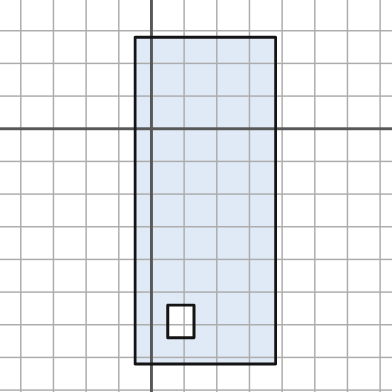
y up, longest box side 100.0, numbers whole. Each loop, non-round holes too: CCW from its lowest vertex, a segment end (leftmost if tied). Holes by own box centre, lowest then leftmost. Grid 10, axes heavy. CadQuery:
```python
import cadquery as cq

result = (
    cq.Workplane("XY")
    .moveTo(-5.0, -72.0)
    .lineTo(38.0, -72.0)
    .lineTo(38.0, 28.0)
    .lineTo(-5.0, 28.0)
    .close()
    .moveTo(5.0, -64.0)
    .lineTo(13.0, -64.0)
    .lineTo(13.0, -54.0)
    .lineTo(5.0, -54.0)
    .close()
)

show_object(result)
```